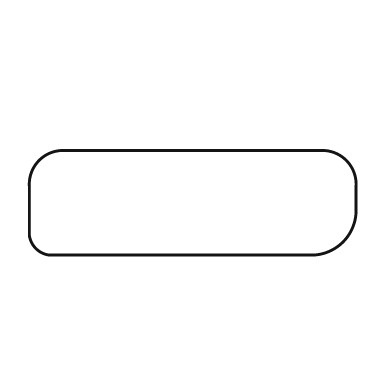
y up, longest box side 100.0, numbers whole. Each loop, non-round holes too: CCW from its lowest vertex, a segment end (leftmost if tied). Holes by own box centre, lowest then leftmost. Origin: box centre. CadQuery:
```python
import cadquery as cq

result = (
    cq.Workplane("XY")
    .moveTo(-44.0, -16.0)
    .lineTo(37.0, -16.0)
    .threePointArc((46.0, -12.0), (50.0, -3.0))
    .lineTo(50.0, 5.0)
    .threePointArc((47.0, 13.0), (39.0, 16.0))
    .lineTo(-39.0, 16.0)
    .threePointArc((-47.0, 13.0), (-50.0, 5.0))
    .lineTo(-50.0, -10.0)
    .threePointArc((-48.0, -14.0), (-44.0, -16.0))
    .close()
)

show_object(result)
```